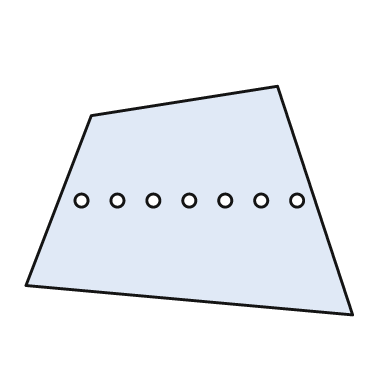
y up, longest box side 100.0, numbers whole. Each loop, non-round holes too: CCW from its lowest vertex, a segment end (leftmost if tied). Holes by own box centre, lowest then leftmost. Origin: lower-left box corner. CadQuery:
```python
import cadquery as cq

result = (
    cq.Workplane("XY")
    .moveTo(100.0, 0.0)
    .lineTo(77.0, 70.0)
    .lineTo(20.0, 61.0)
    .lineTo(0.0, 9.0)
    .close()
    .moveTo(17.0, 35.0)
    .circle(2.0)
    .moveTo(28.0, 35.0)
    .circle(2.0)
    .moveTo(39.0, 35.0)
    .circle(2.0)
    .moveTo(50.0, 35.0)
    .circle(2.0)
    .moveTo(61.0, 35.0)
    .circle(2.0)
    .moveTo(72.0, 35.0)
    .circle(2.0)
    .moveTo(83.0, 35.0)
    .circle(2.0)
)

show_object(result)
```